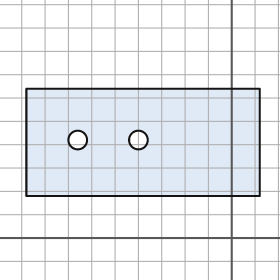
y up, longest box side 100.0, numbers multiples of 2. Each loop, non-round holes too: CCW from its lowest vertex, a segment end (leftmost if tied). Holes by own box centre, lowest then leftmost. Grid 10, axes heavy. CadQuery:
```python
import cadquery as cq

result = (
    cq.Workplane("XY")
    .moveTo(-88.0, 18.0)
    .lineTo(12.0, 18.0)
    .lineTo(12.0, 64.0)
    .lineTo(-88.0, 64.0)
    .close()
    .moveTo(-66.0, 42.0)
    .circle(4.0)
    .moveTo(-40.0, 42.0)
    .circle(4.0)
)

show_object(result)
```